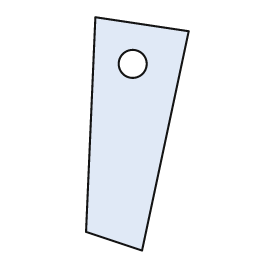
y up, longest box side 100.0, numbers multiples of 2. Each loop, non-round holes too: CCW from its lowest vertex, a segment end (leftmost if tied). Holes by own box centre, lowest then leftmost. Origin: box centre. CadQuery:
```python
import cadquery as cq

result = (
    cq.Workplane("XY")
    .moveTo(2.0, -50.0)
    .lineTo(22.0, 44.0)
    .lineTo(-18.0, 50.0)
    .lineTo(-22.0, -42.0)
    .close()
    .moveTo(-2.0, 30.0)
    .circle(6.0)
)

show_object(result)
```